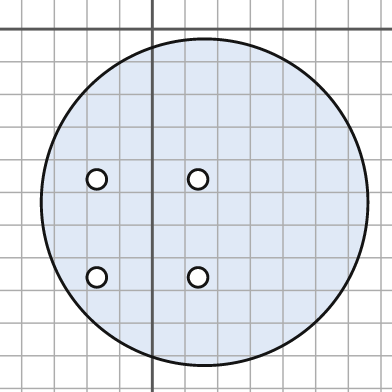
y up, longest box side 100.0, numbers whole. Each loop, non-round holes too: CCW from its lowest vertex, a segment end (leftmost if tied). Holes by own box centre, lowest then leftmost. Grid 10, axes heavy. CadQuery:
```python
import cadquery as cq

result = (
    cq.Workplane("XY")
    .moveTo(16.0, -53.0)
    .circle(50.0)
    .moveTo(-17.0, -76.0)
    .circle(3.0)
    .moveTo(14.0, -76.0)
    .circle(3.0)
    .moveTo(-17.0, -46.0)
    .circle(3.0)
    .moveTo(14.0, -46.0)
    .circle(3.0)
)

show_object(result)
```